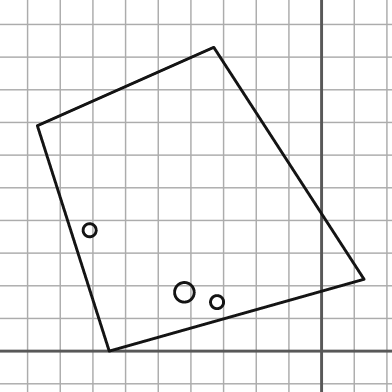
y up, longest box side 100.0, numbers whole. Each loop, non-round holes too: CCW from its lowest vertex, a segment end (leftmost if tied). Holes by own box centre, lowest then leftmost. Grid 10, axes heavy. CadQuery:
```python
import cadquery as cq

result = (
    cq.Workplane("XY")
    .moveTo(-65.0, 0.0)
    .lineTo(13.0, 22.0)
    .lineTo(-33.0, 93.0)
    .lineTo(-87.0, 69.0)
    .close()
    .moveTo(-32.0, 15.0)
    .circle(2.0)
    .moveTo(-42.0, 18.0)
    .circle(3.0)
    .moveTo(-71.0, 37.0)
    .circle(2.0)
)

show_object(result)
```